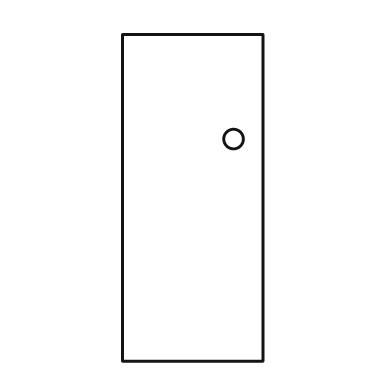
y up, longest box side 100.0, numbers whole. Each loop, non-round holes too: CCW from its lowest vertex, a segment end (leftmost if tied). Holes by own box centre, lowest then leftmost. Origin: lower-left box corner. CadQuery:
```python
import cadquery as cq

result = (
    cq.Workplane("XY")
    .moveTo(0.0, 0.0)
    .lineTo(43.0, 0.0)
    .lineTo(43.0, 100.0)
    .lineTo(0.0, 100.0)
    .close()
    .moveTo(34.0, 68.0)
    .circle(3.0)
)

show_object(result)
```